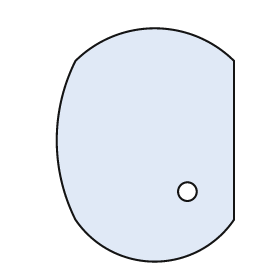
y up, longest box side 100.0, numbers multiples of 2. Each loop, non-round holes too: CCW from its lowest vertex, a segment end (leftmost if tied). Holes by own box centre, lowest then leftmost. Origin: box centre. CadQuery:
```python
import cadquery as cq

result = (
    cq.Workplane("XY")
    .moveTo(-30.0, -32.0)
    .threePointArc((4.0, -50.0), (38.0, -32.0))
    .lineTo(38.0, 36.0)
    .threePointArc((4.0, 50.0), (-30.0, 36.0))
    .threePointArc((-38.0, 2.0), (-30.0, -32.0))
    .close()
    .moveTo(18.0, -20.0)
    .circle(4.0)
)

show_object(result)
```